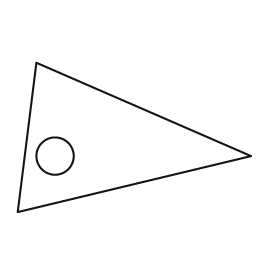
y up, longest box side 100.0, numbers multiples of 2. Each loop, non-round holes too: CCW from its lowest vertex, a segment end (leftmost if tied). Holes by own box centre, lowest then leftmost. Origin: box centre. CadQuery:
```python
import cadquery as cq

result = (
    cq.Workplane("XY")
    .moveTo(-50.0, -32.0)
    .lineTo(50.0, -8.0)
    .lineTo(-42.0, 32.0)
    .close()
    .moveTo(-34.0, -8.0)
    .circle(8.0)
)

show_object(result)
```